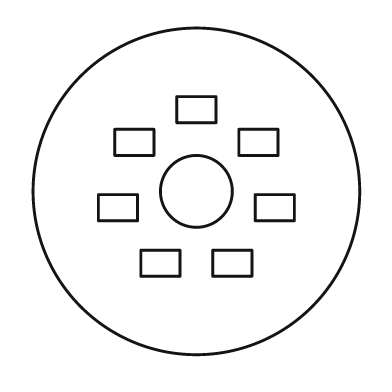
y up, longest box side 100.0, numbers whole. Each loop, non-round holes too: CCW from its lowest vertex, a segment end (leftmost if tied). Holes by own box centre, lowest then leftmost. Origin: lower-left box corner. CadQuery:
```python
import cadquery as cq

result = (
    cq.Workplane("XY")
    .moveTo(50.0, 50.0)
    .circle(50.0)
    .moveTo(33.0, 24.0)
    .lineTo(45.0, 24.0)
    .lineTo(45.0, 32.0)
    .lineTo(33.0, 32.0)
    .close()
    .moveTo(55.0, 24.0)
    .lineTo(67.0, 24.0)
    .lineTo(67.0, 32.0)
    .lineTo(55.0, 32.0)
    .close()
    .moveTo(20.0, 41.0)
    .lineTo(32.0, 41.0)
    .lineTo(32.0, 49.0)
    .lineTo(20.0, 49.0)
    .close()
    .moveTo(68.0, 41.0)
    .lineTo(80.0, 41.0)
    .lineTo(80.0, 49.0)
    .lineTo(68.0, 49.0)
    .close()
    .moveTo(50.0, 50.0)
    .circle(11.0)
    .moveTo(25.0, 61.0)
    .lineTo(37.0, 61.0)
    .lineTo(37.0, 69.0)
    .lineTo(25.0, 69.0)
    .close()
    .moveTo(63.0, 61.0)
    .lineTo(75.0, 61.0)
    .lineTo(75.0, 69.0)
    .lineTo(63.0, 69.0)
    .close()
    .moveTo(44.0, 71.0)
    .lineTo(56.0, 71.0)
    .lineTo(56.0, 79.0)
    .lineTo(44.0, 79.0)
    .close()
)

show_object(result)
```